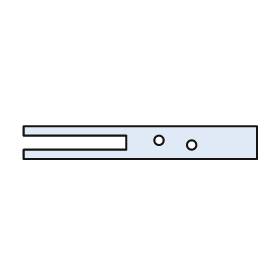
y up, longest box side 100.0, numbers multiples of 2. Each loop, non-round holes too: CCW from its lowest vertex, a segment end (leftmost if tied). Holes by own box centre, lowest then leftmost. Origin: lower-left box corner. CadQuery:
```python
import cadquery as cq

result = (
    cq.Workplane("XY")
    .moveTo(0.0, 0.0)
    .lineTo(100.0, 0.0)
    .lineTo(100.0, 14.0)
    .lineTo(0.0, 14.0)
    .lineTo(0.0, 10.0)
    .lineTo(44.0, 10.0)
    .lineTo(44.0, 4.0)
    .lineTo(0.0, 4.0)
    .close()
    .moveTo(72.0, 6.0)
    .circle(2.0)
    .moveTo(58.0, 8.0)
    .circle(2.0)
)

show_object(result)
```